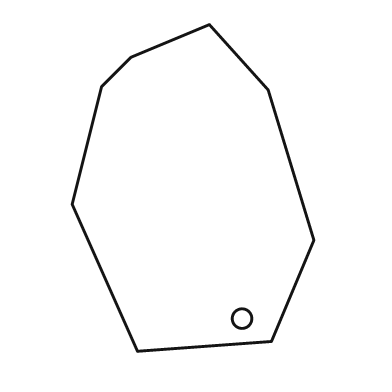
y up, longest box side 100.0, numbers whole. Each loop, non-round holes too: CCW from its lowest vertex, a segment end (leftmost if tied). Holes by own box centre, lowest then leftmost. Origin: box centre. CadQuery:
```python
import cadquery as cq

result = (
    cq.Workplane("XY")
    .moveTo(-17.0, -50.0)
    .lineTo(24.0, -47.0)
    .lineTo(37.0, -16.0)
    .lineTo(23.0, 30.0)
    .lineTo(5.0, 50.0)
    .lineTo(-19.0, 40.0)
    .lineTo(-28.0, 31.0)
    .lineTo(-37.0, -5.0)
    .close()
    .moveTo(15.0, -40.0)
    .circle(3.0)
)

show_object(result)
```